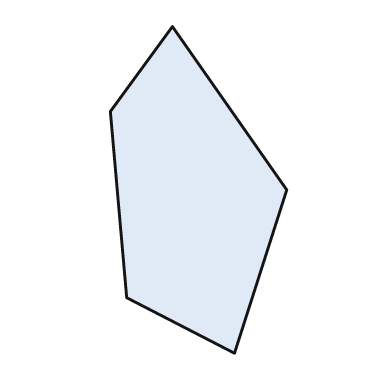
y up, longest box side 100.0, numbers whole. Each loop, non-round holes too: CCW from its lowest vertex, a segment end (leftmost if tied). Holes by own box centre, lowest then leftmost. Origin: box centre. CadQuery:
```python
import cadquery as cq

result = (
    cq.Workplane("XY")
    .moveTo(11.0, -50.0)
    .lineTo(27.0, 0.0)
    .lineTo(-8.0, 50.0)
    .lineTo(-27.0, 24.0)
    .lineTo(-22.0, -33.0)
    .close()
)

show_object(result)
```